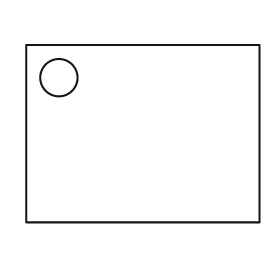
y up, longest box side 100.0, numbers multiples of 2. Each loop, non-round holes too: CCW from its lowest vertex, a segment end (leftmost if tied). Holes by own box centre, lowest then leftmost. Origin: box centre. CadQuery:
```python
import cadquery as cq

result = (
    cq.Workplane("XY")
    .moveTo(-50.0, -38.0)
    .lineTo(50.0, -38.0)
    .lineTo(50.0, 38.0)
    .lineTo(-50.0, 38.0)
    .close()
    .moveTo(-36.0, 24.0)
    .circle(8.0)
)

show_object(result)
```